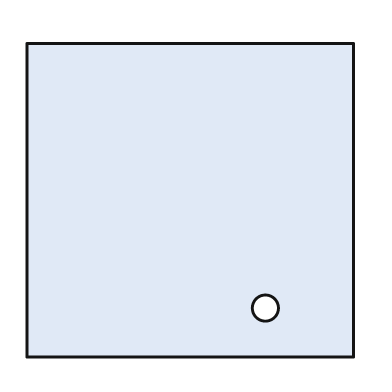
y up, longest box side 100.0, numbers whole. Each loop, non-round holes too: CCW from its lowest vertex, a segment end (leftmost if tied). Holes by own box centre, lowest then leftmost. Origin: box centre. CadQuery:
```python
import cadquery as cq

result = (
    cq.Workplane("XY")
    .moveTo(-50.0, -48.0)
    .lineTo(50.0, -48.0)
    .lineTo(50.0, 48.0)
    .lineTo(-50.0, 48.0)
    .close()
    .moveTo(23.0, -33.0)
    .circle(4.0)
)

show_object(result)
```